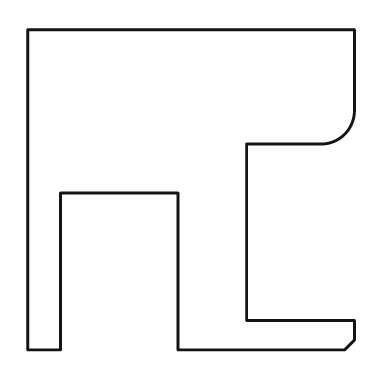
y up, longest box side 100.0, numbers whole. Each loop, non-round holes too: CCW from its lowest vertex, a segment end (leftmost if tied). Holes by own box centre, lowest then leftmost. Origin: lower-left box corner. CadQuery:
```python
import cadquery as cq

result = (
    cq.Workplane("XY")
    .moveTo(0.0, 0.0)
    .lineTo(10.0, 0.0)
    .lineTo(10.0, 48.0)
    .lineTo(46.0, 48.0)
    .lineTo(46.0, 0.0)
    .lineTo(97.0, 0.0)
    .lineTo(100.0, 3.0)
    .lineTo(100.0, 9.0)
    .lineTo(67.0, 9.0)
    .lineTo(67.0, 63.0)
    .lineTo(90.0, 63.0)
    .threePointArc((97.0, 66.0), (100.0, 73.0))
    .lineTo(100.0, 98.0)
    .lineTo(0.0, 98.0)
    .close()
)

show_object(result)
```